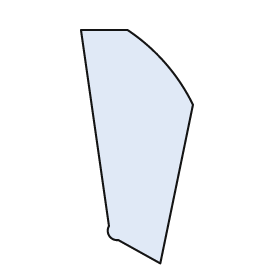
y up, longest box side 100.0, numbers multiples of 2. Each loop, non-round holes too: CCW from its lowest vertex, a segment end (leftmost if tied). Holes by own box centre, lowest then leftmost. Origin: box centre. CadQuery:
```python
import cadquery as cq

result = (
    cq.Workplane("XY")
    .moveTo(10.0, -50.0)
    .lineTo(24.0, 18.0)
    .threePointArc((12.0, 36.0), (-4.0, 50.0))
    .lineTo(-24.0, 50.0)
    .lineTo(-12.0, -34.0)
    .threePointArc((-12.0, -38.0), (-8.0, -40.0))
    .close()
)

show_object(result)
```